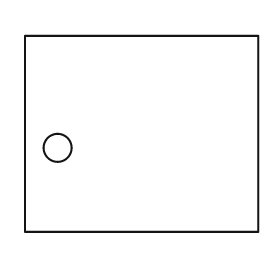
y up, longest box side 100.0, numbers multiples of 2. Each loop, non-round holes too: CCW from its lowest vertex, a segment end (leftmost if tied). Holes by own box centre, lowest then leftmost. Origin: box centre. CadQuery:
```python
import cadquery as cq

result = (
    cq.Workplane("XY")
    .moveTo(-50.0, -42.0)
    .lineTo(50.0, -42.0)
    .lineTo(50.0, 42.0)
    .lineTo(-50.0, 42.0)
    .close()
    .moveTo(-36.0, -6.0)
    .circle(6.0)
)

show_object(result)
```